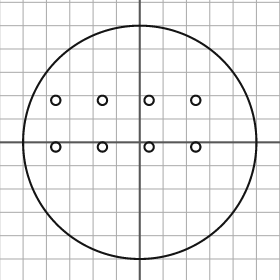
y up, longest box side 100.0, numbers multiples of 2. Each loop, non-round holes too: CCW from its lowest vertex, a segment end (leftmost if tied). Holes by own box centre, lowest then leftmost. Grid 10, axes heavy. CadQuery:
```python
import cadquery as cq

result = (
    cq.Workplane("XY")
    .moveTo(0.0, 0.0)
    .circle(50.0)
    .moveTo(-36.0, -2.0)
    .circle(2.0)
    .moveTo(-16.0, -2.0)
    .circle(2.0)
    .moveTo(4.0, -2.0)
    .circle(2.0)
    .moveTo(24.0, -2.0)
    .circle(2.0)
    .moveTo(-36.0, 18.0)
    .circle(2.0)
    .moveTo(-16.0, 18.0)
    .circle(2.0)
    .moveTo(4.0, 18.0)
    .circle(2.0)
    .moveTo(24.0, 18.0)
    .circle(2.0)
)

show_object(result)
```